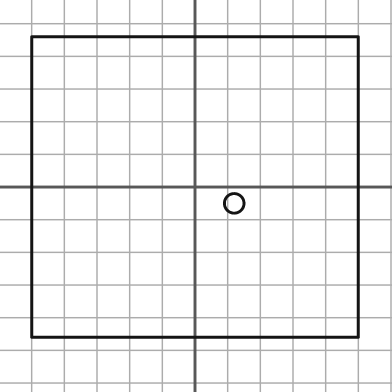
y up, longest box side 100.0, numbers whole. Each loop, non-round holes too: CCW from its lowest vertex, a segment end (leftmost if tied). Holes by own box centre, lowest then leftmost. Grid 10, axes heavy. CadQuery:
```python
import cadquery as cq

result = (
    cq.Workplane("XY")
    .moveTo(-50.0, -46.0)
    .lineTo(50.0, -46.0)
    .lineTo(50.0, 46.0)
    .lineTo(-50.0, 46.0)
    .close()
    .moveTo(12.0, -5.0)
    .circle(3.0)
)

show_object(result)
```